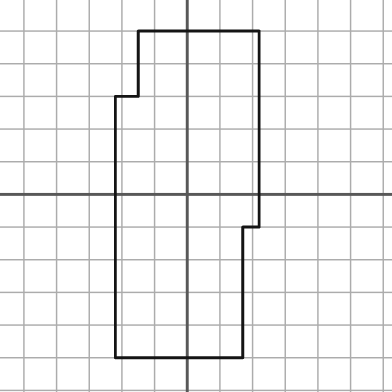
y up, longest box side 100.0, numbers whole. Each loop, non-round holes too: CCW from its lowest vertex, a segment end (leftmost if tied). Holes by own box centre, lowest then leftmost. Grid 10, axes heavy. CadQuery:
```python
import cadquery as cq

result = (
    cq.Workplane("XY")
    .moveTo(-22.0, -50.0)
    .lineTo(17.0, -50.0)
    .lineTo(17.0, -10.0)
    .lineTo(22.0, -10.0)
    .lineTo(22.0, 50.0)
    .lineTo(-15.0, 50.0)
    .lineTo(-15.0, 30.0)
    .lineTo(-22.0, 30.0)
    .close()
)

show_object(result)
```